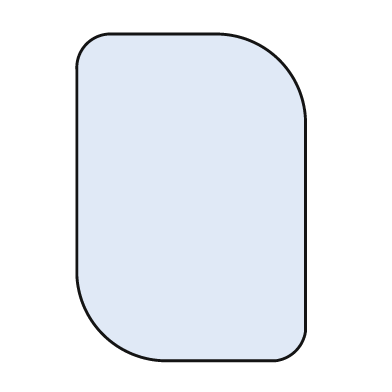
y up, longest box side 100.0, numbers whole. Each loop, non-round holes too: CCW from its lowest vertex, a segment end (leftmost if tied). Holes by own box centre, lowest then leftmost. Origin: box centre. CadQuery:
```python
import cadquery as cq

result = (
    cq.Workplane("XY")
    .moveTo(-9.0, -50.0)
    .lineTo(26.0, -50.0)
    .threePointArc((32.0, -47.0), (35.0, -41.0))
    .lineTo(35.0, 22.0)
    .threePointArc((27.0, 42.0), (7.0, 50.0))
    .lineTo(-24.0, 50.0)
    .threePointArc((-32.0, 47.0), (-35.0, 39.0))
    .lineTo(-35.0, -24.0)
    .threePointArc((-27.0, -42.0), (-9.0, -50.0))
    .close()
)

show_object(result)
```